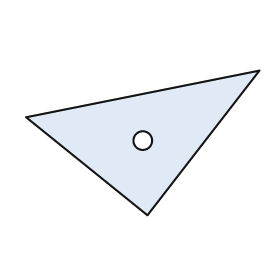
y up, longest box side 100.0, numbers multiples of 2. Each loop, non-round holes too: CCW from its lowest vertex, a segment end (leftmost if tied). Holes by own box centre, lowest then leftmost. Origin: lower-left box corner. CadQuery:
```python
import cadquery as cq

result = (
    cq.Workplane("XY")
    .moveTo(52.0, 0.0)
    .lineTo(100.0, 62.0)
    .lineTo(0.0, 42.0)
    .close()
    .moveTo(50.0, 32.0)
    .circle(4.0)
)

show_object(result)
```